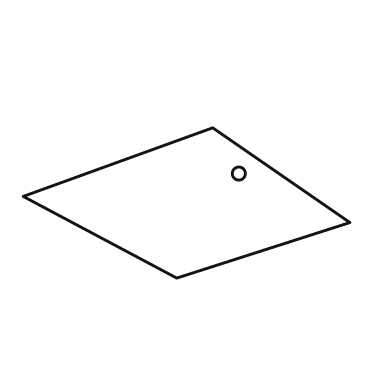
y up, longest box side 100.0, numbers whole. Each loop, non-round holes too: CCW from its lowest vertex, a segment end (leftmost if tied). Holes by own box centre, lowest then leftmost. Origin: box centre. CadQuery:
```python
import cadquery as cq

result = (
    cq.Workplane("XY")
    .moveTo(-3.0, -23.0)
    .lineTo(50.0, -6.0)
    .lineTo(8.0, 23.0)
    .lineTo(-50.0, 2.0)
    .close()
    .moveTo(16.0, 9.0)
    .circle(2.0)
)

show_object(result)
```